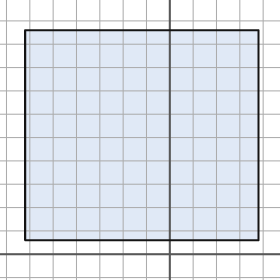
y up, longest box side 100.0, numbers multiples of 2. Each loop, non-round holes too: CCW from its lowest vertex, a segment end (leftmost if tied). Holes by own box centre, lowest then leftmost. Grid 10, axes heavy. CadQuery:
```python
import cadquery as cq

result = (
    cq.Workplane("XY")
    .moveTo(-62.0, 6.0)
    .lineTo(38.0, 6.0)
    .lineTo(38.0, 96.0)
    .lineTo(-62.0, 96.0)
    .close()
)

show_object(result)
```